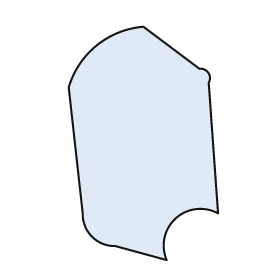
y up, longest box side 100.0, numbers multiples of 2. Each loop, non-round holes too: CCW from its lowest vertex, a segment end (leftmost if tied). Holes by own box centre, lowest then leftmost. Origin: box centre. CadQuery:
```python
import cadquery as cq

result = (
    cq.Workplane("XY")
    .moveTo(10.0, -50.0)
    .threePointArc((14.0, -32.0), (32.0, -30.0))
    .lineTo(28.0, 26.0)
    .threePointArc((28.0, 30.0), (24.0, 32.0))
    .lineTo(0.0, 50.0)
    .threePointArc((-20.0, 42.0), (-32.0, 24.0))
    .lineTo(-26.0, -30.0)
    .threePointArc((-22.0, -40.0), (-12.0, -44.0))
    .close()
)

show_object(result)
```